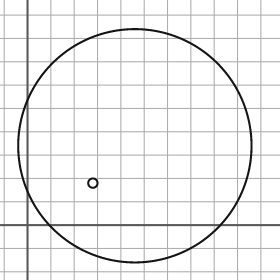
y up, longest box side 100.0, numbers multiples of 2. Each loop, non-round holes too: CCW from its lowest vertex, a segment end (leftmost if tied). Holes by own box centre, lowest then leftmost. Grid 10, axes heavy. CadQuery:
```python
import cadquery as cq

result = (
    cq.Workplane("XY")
    .moveTo(46.0, 34.0)
    .circle(50.0)
    .moveTo(28.0, 18.0)
    .circle(2.0)
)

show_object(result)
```